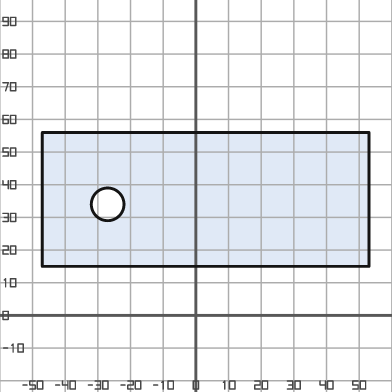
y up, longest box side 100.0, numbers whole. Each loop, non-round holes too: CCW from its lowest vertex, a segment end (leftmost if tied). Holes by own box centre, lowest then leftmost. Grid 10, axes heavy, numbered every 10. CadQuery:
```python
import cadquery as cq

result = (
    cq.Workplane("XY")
    .moveTo(-47.0, 15.0)
    .lineTo(53.0, 15.0)
    .lineTo(53.0, 56.0)
    .lineTo(-47.0, 56.0)
    .close()
    .moveTo(-27.0, 34.0)
    .circle(5.0)
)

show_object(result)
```